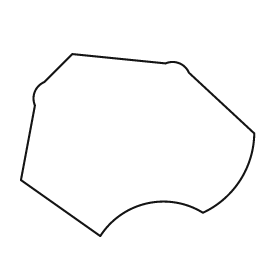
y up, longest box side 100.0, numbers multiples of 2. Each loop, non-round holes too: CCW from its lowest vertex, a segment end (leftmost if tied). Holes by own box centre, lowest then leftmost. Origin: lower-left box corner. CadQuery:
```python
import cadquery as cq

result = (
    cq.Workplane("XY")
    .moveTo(34.0, 0.0)
    .threePointArc((54.0, 14.0), (78.0, 10.0))
    .threePointArc((94.0, 24.0), (100.0, 44.0))
    .lineTo(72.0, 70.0)
    .threePointArc((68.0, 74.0), (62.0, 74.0))
    .lineTo(22.0, 78.0)
    .lineTo(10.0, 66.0)
    .threePointArc((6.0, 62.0), (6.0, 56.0))
    .lineTo(0.0, 24.0)
    .close()
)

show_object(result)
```